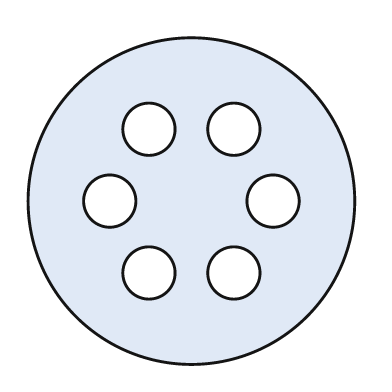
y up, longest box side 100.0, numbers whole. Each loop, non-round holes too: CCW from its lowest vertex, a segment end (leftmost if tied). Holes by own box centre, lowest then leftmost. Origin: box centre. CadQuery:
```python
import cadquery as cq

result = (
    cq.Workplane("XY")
    .moveTo(0.0, 0.0)
    .circle(50.0)
    .moveTo(-13.0, -22.0)
    .circle(8.0)
    .moveTo(13.0, -22.0)
    .circle(8.0)
    .moveTo(-25.0, 0.0)
    .circle(8.0)
    .moveTo(25.0, 0.0)
    .circle(8.0)
    .moveTo(-13.0, 22.0)
    .circle(8.0)
    .moveTo(13.0, 22.0)
    .circle(8.0)
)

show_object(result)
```